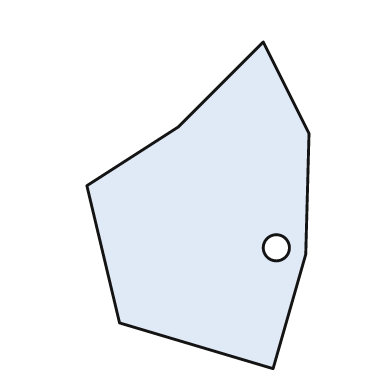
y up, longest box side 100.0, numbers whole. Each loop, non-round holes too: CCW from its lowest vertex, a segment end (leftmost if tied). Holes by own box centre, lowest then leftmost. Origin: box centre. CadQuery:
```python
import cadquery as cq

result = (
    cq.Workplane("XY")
    .moveTo(23.0, -50.0)
    .lineTo(33.0, -15.0)
    .lineTo(34.0, 22.0)
    .lineTo(20.0, 50.0)
    .lineTo(-6.0, 24.0)
    .lineTo(-34.0, 6.0)
    .lineTo(-24.0, -36.0)
    .close()
    .moveTo(24.0, -13.0)
    .circle(4.0)
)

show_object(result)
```